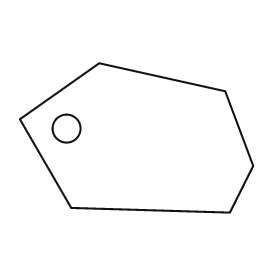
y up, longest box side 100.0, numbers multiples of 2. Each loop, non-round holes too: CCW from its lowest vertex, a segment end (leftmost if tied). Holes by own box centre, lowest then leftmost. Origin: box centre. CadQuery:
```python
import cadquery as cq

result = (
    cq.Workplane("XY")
    .moveTo(40.0, -32.0)
    .lineTo(50.0, -12.0)
    .lineTo(38.0, 20.0)
    .lineTo(-16.0, 32.0)
    .lineTo(-50.0, 8.0)
    .lineTo(-28.0, -30.0)
    .close()
    .moveTo(-30.0, 4.0)
    .circle(6.0)
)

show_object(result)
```